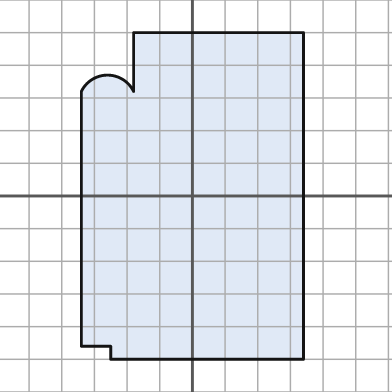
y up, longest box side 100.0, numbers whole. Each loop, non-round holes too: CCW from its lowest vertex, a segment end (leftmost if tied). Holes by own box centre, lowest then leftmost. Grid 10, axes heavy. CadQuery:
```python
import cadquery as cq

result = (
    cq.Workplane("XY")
    .moveTo(-25.0, -50.0)
    .lineTo(34.0, -50.0)
    .lineTo(34.0, 50.0)
    .lineTo(-18.0, 50.0)
    .lineTo(-18.0, 32.0)
    .threePointArc((-26.0, 37.0), (-34.0, 32.0))
    .lineTo(-34.0, -46.0)
    .lineTo(-25.0, -46.0)
    .close()
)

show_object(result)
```